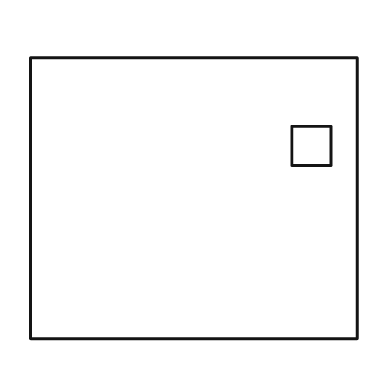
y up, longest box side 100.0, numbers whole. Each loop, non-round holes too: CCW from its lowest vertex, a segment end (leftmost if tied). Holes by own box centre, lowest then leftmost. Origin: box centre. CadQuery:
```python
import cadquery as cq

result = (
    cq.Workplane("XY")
    .moveTo(-50.0, -43.0)
    .lineTo(50.0, -43.0)
    .lineTo(50.0, 43.0)
    .lineTo(-50.0, 43.0)
    .close()
    .moveTo(30.0, 10.0)
    .lineTo(42.0, 10.0)
    .lineTo(42.0, 22.0)
    .lineTo(30.0, 22.0)
    .close()
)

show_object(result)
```